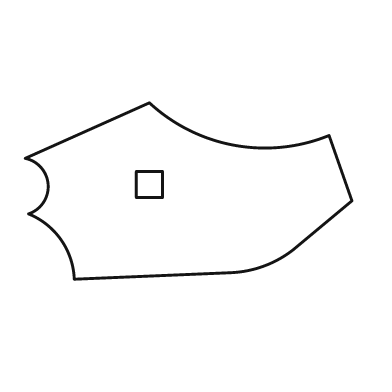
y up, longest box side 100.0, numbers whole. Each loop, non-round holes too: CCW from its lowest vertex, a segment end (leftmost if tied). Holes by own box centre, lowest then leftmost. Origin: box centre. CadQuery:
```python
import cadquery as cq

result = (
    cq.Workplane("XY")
    .moveTo(-35.0, -27.0)
    .lineTo(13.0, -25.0)
    .threePointArc((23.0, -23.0), (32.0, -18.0))
    .lineTo(50.0, -3.0)
    .lineTo(43.0, 17.0)
    .threePointArc((14.0, 14.0), (-12.0, 27.0))
    .lineTo(-50.0, 10.0)
    .threePointArc((-43.0, 2.0), (-49.0, -7.0))
    .threePointArc((-39.0, -15.0), (-35.0, -27.0))
    .close()
    .moveTo(-16.0, -2.0)
    .lineTo(-8.0, -2.0)
    .lineTo(-8.0, 6.0)
    .lineTo(-16.0, 6.0)
    .close()
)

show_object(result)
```